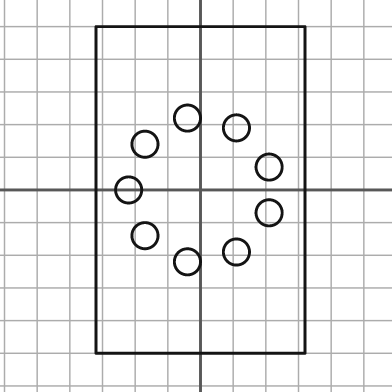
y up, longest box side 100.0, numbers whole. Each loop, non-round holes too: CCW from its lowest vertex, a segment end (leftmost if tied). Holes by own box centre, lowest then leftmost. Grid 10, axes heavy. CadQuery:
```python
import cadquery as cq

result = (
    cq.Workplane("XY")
    .moveTo(-32.0, -50.0)
    .lineTo(32.0, -50.0)
    .lineTo(32.0, 50.0)
    .lineTo(-32.0, 50.0)
    .close()
    .moveTo(-4.0, -22.0)
    .circle(4.0)
    .moveTo(11.0, -19.0)
    .circle(4.0)
    .moveTo(-17.0, -14.0)
    .circle(4.0)
    .moveTo(21.0, -7.0)
    .circle(4.0)
    .moveTo(-22.0, 0.0)
    .circle(4.0)
    .moveTo(21.0, 7.0)
    .circle(4.0)
    .moveTo(-17.0, 14.0)
    .circle(4.0)
    .moveTo(11.0, 19.0)
    .circle(4.0)
    .moveTo(-4.0, 22.0)
    .circle(4.0)
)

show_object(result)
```